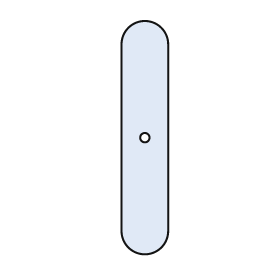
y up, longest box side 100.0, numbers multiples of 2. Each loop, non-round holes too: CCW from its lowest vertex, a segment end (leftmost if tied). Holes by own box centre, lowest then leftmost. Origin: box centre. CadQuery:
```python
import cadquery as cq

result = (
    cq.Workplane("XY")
    .moveTo(-10.0, -40.0)
    .threePointArc((0.0, -50.0), (10.0, -40.0))
    .lineTo(10.0, 40.0)
    .threePointArc((0.0, 50.0), (-10.0, 40.0))
    .close()
    .moveTo(0.0, 0.0)
    .circle(2.0)
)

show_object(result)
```